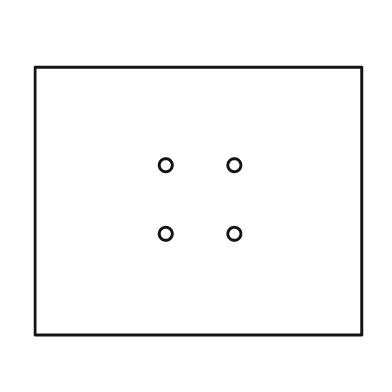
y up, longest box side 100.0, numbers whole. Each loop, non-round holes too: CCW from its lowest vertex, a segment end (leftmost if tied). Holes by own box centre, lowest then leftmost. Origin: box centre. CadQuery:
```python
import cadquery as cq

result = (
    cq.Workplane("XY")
    .moveTo(-50.0, -41.0)
    .lineTo(50.0, -41.0)
    .lineTo(50.0, 41.0)
    .lineTo(-50.0, 41.0)
    .close()
    .moveTo(-10.0, -10.0)
    .circle(2.0)
    .moveTo(11.0, -10.0)
    .circle(2.0)
    .moveTo(-10.0, 11.0)
    .circle(2.0)
    .moveTo(11.0, 11.0)
    .circle(2.0)
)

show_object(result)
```